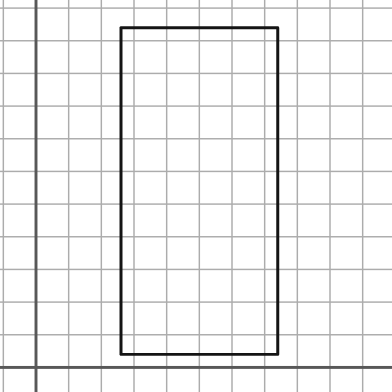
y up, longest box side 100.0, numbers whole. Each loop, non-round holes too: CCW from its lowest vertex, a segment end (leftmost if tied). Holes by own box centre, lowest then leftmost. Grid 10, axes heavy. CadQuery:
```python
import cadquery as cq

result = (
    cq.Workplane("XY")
    .moveTo(26.0, 4.0)
    .lineTo(74.0, 4.0)
    .lineTo(74.0, 104.0)
    .lineTo(26.0, 104.0)
    .close()
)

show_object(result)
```